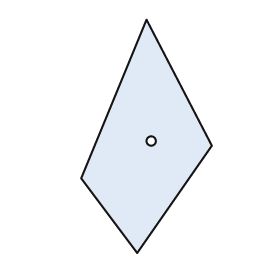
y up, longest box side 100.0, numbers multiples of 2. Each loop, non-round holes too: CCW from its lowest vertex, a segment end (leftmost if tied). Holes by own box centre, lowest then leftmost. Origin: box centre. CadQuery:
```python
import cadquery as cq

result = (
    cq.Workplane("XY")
    .moveTo(-4.0, -50.0)
    .lineTo(28.0, -4.0)
    .lineTo(0.0, 50.0)
    .lineTo(-28.0, -18.0)
    .close()
    .moveTo(2.0, -2.0)
    .circle(2.0)
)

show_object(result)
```